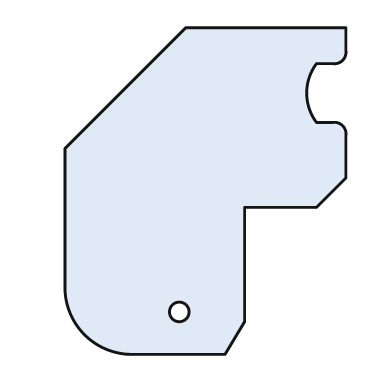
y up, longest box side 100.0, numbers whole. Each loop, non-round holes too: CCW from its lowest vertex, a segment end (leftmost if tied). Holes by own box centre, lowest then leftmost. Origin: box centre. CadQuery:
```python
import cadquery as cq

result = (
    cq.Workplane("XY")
    .moveTo(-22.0, -50.0)
    .lineTo(6.0, -50.0)
    .lineTo(12.0, -40.0)
    .lineTo(12.0, -5.0)
    .lineTo(34.0, -5.0)
    .lineTo(43.0, 4.0)
    .lineTo(43.0, 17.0)
    .threePointArc((42.0, 20.0), (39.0, 21.0))
    .lineTo(34.0, 21.0)
    .threePointArc((31.0, 30.0), (34.0, 39.0))
    .lineTo(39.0, 39.0)
    .threePointArc((42.0, 40.0), (43.0, 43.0))
    .lineTo(43.0, 50.0)
    .lineTo(-6.0, 50.0)
    .lineTo(-43.0, 13.0)
    .lineTo(-43.0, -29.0)
    .threePointArc((-37.0, -44.0), (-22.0, -50.0))
    .close()
    .moveTo(-8.0, -37.0)
    .circle(3.0)
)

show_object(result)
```